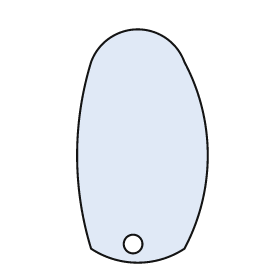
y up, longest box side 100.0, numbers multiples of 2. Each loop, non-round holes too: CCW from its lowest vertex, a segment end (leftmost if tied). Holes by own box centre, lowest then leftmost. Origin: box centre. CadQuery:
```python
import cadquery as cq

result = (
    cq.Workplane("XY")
    .moveTo(-22.0, -44.0)
    .threePointArc((-2.0, -50.0), (18.0, -44.0))
    .threePointArc((28.0, -4.0), (18.0, 36.0))
    .threePointArc((-2.0, 50.0), (-22.0, 36.0))
    .threePointArc((-28.0, -4.0), (-22.0, -44.0))
    .close()
    .moveTo(-4.0, -42.0)
    .circle(4.0)
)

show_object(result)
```